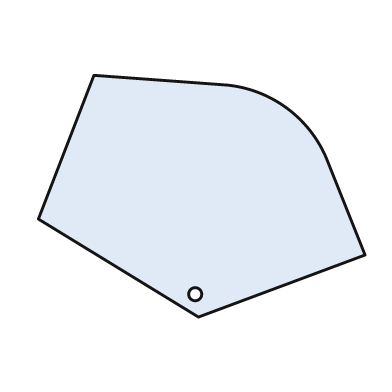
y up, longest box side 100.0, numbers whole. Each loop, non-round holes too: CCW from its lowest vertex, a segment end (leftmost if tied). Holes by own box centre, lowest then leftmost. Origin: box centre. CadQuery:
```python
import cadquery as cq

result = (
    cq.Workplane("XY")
    .moveTo(-1.0, -37.0)
    .lineTo(50.0, -18.0)
    .lineTo(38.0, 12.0)
    .threePointArc((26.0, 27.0), (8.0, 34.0))
    .lineTo(-33.0, 37.0)
    .lineTo(-50.0, -7.0)
    .close()
    .moveTo(-2.0, -30.0)
    .circle(2.0)
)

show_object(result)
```